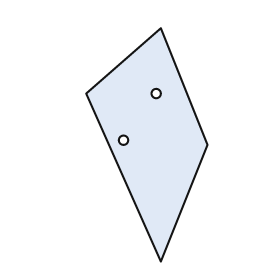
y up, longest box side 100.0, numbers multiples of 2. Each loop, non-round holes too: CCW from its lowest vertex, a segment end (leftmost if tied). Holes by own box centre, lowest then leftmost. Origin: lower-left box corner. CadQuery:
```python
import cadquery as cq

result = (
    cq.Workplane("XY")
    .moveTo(32.0, 0.0)
    .lineTo(52.0, 50.0)
    .lineTo(32.0, 100.0)
    .lineTo(0.0, 72.0)
    .close()
    .moveTo(16.0, 52.0)
    .circle(2.0)
    .moveTo(30.0, 72.0)
    .circle(2.0)
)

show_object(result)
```